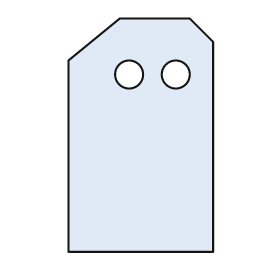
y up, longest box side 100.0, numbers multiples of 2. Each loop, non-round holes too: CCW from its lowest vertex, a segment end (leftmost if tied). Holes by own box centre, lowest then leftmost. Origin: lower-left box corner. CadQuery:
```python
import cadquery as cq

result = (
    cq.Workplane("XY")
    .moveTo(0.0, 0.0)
    .lineTo(62.0, 0.0)
    .lineTo(62.0, 90.0)
    .lineTo(52.0, 100.0)
    .lineTo(22.0, 100.0)
    .lineTo(0.0, 82.0)
    .close()
    .moveTo(26.0, 76.0)
    .circle(6.0)
    .moveTo(46.0, 76.0)
    .circle(6.0)
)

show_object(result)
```